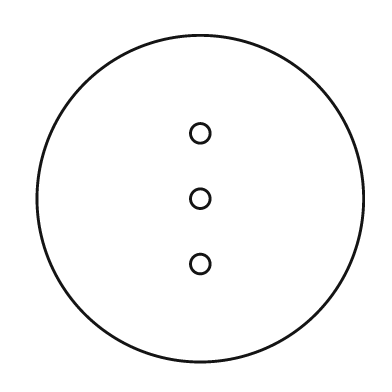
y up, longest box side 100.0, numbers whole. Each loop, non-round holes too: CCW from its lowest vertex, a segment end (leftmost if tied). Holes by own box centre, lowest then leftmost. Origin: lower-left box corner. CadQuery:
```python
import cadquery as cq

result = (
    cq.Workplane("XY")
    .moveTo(50.0, 50.0)
    .circle(50.0)
    .moveTo(50.0, 30.0)
    .circle(3.0)
    .moveTo(50.0, 50.0)
    .circle(3.0)
    .moveTo(50.0, 70.0)
    .circle(3.0)
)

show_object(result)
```